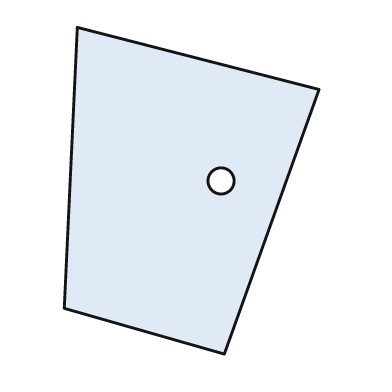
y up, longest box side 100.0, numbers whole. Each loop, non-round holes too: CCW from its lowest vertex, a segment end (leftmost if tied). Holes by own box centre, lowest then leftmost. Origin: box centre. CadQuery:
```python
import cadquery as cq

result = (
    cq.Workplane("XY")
    .moveTo(10.0, -50.0)
    .lineTo(39.0, 31.0)
    .lineTo(-35.0, 50.0)
    .lineTo(-39.0, -36.0)
    .close()
    .moveTo(9.0, 3.0)
    .circle(4.0)
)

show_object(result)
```